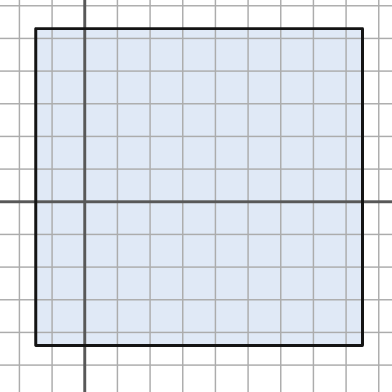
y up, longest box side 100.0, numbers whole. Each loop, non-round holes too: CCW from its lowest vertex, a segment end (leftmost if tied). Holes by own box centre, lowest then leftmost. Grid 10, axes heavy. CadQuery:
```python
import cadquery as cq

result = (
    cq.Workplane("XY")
    .moveTo(-15.0, -44.0)
    .lineTo(85.0, -44.0)
    .lineTo(85.0, 53.0)
    .lineTo(-15.0, 53.0)
    .close()
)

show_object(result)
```